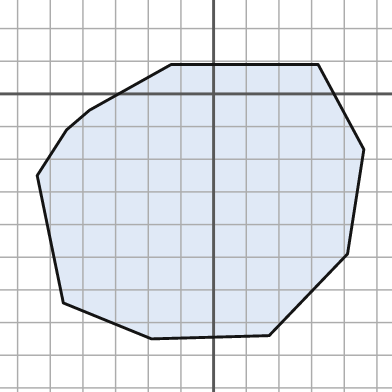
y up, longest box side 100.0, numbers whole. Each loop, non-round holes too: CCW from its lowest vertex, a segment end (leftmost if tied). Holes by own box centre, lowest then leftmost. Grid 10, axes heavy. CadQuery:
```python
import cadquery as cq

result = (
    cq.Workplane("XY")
    .moveTo(-19.0, -75.0)
    .lineTo(17.0, -74.0)
    .lineTo(41.0, -49.0)
    .lineTo(46.0, -17.0)
    .lineTo(32.0, 9.0)
    .lineTo(-13.0, 9.0)
    .lineTo(-38.0, -5.0)
    .lineTo(-45.0, -11.0)
    .lineTo(-54.0, -25.0)
    .lineTo(-46.0, -64.0)
    .close()
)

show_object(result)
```